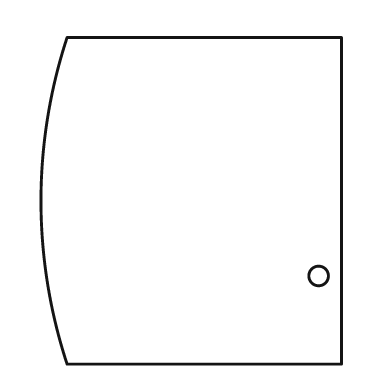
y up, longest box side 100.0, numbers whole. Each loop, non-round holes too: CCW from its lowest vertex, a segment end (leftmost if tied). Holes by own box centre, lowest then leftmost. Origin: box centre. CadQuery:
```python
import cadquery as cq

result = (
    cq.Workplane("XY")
    .moveTo(-38.0, -50.0)
    .lineTo(46.0, -50.0)
    .lineTo(46.0, 50.0)
    .lineTo(-38.0, 50.0)
    .threePointArc((-46.0, 0.0), (-38.0, -50.0))
    .close()
    .moveTo(39.0, -23.0)
    .circle(3.0)
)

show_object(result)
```